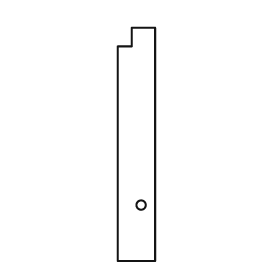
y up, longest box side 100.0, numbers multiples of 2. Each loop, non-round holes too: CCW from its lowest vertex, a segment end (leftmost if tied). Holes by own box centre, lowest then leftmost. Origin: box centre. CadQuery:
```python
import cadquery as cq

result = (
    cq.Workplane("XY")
    .moveTo(-8.0, -50.0)
    .lineTo(8.0, -50.0)
    .lineTo(8.0, 50.0)
    .lineTo(-2.0, 50.0)
    .lineTo(-2.0, 42.0)
    .lineTo(-8.0, 42.0)
    .close()
    .moveTo(2.0, -26.0)
    .circle(2.0)
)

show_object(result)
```